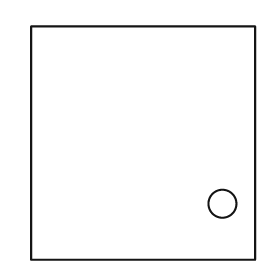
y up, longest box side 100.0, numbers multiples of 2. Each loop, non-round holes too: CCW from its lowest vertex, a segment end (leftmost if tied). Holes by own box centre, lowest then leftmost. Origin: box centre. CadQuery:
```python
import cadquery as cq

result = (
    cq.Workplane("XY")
    .moveTo(-48.0, -50.0)
    .lineTo(48.0, -50.0)
    .lineTo(48.0, 50.0)
    .lineTo(-48.0, 50.0)
    .close()
    .moveTo(34.0, -26.0)
    .circle(6.0)
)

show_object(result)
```